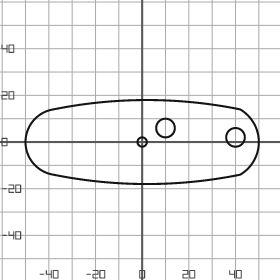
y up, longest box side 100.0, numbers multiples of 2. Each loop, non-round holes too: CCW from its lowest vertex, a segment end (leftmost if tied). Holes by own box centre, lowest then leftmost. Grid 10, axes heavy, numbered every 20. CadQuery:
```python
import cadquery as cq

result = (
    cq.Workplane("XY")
    .moveTo(-38.0, -14.0)
    .threePointArc((2.0, -18.0), (42.0, -14.0))
    .threePointArc((50.0, 0.0), (42.0, 14.0))
    .threePointArc((2.0, 18.0), (-38.0, 14.0))
    .threePointArc((-50.0, 0.0), (-38.0, -14.0))
    .close()
    .moveTo(0.0, 0.0)
    .circle(2.0)
    .moveTo(40.0, 2.0)
    .circle(4.0)
    .moveTo(10.0, 6.0)
    .circle(4.0)
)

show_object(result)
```